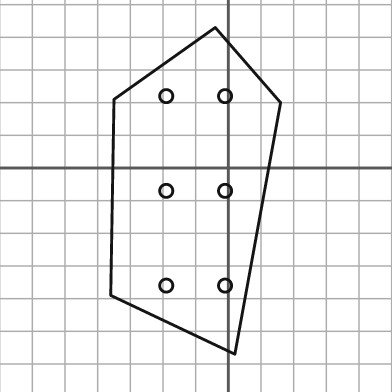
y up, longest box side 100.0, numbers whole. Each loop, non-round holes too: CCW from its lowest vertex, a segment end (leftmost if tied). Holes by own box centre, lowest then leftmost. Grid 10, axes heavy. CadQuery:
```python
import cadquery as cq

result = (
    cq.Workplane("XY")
    .moveTo(2.0, -57.0)
    .lineTo(16.0, 20.0)
    .lineTo(-4.0, 43.0)
    .lineTo(-35.0, 21.0)
    .lineTo(-36.0, -39.0)
    .close()
    .moveTo(-19.0, -36.0)
    .circle(2.0)
    .moveTo(-1.0, -36.0)
    .circle(2.0)
    .moveTo(-19.0, -7.0)
    .circle(2.0)
    .moveTo(-1.0, -7.0)
    .circle(2.0)
    .moveTo(-19.0, 22.0)
    .circle(2.0)
    .moveTo(-1.0, 22.0)
    .circle(2.0)
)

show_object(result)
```